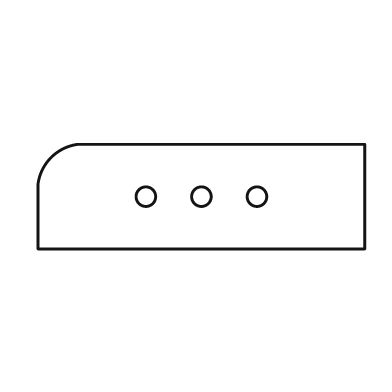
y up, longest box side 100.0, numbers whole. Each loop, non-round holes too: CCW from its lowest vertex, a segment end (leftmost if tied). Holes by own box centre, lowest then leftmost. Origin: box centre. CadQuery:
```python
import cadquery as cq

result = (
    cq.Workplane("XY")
    .moveTo(-50.0, -16.0)
    .lineTo(50.0, -16.0)
    .lineTo(50.0, 16.0)
    .lineTo(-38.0, 16.0)
    .threePointArc((-46.0, 12.0), (-50.0, 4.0))
    .close()
    .moveTo(-17.0, 0.0)
    .circle(3.0)
    .moveTo(0.0, 0.0)
    .circle(3.0)
    .moveTo(17.0, 0.0)
    .circle(3.0)
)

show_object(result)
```